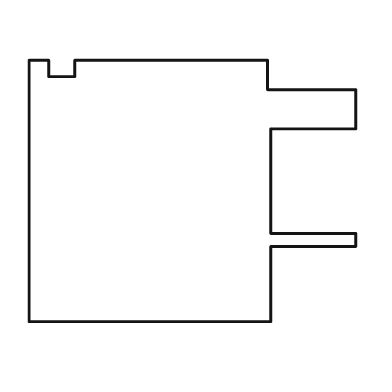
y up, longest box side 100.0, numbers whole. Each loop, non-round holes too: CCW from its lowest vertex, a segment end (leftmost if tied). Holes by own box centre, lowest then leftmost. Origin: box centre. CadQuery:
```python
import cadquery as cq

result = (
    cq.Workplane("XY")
    .moveTo(-50.0, -40.0)
    .lineTo(24.0, -40.0)
    .lineTo(24.0, -17.0)
    .lineTo(50.0, -17.0)
    .lineTo(50.0, -13.0)
    .lineTo(24.0, -13.0)
    .lineTo(24.0, 19.0)
    .lineTo(50.0, 19.0)
    .lineTo(50.0, 31.0)
    .lineTo(23.0, 31.0)
    .lineTo(23.0, 40.0)
    .lineTo(-36.0, 40.0)
    .lineTo(-36.0, 35.0)
    .lineTo(-44.0, 35.0)
    .lineTo(-44.0, 40.0)
    .lineTo(-50.0, 40.0)
    .close()
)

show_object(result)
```